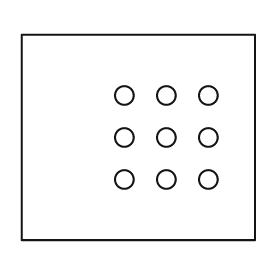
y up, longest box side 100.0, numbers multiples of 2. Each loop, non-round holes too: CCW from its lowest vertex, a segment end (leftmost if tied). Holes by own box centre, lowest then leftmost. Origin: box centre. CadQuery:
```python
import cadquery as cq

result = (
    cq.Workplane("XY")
    .moveTo(-50.0, -44.0)
    .lineTo(50.0, -44.0)
    .lineTo(50.0, 44.0)
    .lineTo(-50.0, 44.0)
    .close()
    .moveTo(-6.0, -18.0)
    .circle(4.0)
    .moveTo(12.0, -18.0)
    .circle(4.0)
    .moveTo(30.0, -18.0)
    .circle(4.0)
    .moveTo(-6.0, 0.0)
    .circle(4.0)
    .moveTo(12.0, 0.0)
    .circle(4.0)
    .moveTo(30.0, 0.0)
    .circle(4.0)
    .moveTo(-6.0, 18.0)
    .circle(4.0)
    .moveTo(12.0, 18.0)
    .circle(4.0)
    .moveTo(30.0, 18.0)
    .circle(4.0)
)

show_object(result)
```